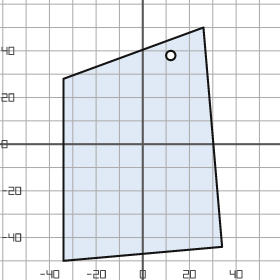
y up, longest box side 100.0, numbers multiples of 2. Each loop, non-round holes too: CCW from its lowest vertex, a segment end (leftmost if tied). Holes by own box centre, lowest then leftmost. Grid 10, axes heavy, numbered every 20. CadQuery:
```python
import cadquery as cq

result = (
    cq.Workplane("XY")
    .moveTo(-34.0, -50.0)
    .lineTo(34.0, -44.0)
    .lineTo(26.0, 50.0)
    .lineTo(-34.0, 28.0)
    .close()
    .moveTo(12.0, 38.0)
    .circle(2.0)
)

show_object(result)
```